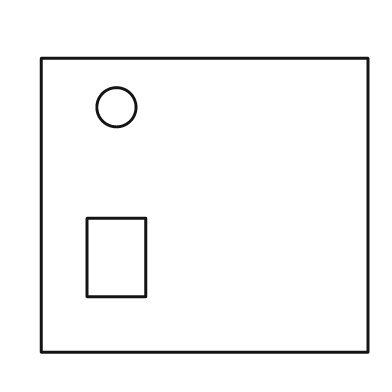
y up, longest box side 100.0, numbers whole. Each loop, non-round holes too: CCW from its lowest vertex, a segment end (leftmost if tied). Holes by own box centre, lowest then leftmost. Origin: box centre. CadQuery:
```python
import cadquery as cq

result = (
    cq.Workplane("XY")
    .moveTo(-50.0, -45.0)
    .lineTo(50.0, -45.0)
    .lineTo(50.0, 45.0)
    .lineTo(-50.0, 45.0)
    .close()
    .moveTo(-36.0, -28.0)
    .lineTo(-18.0, -28.0)
    .lineTo(-18.0, -4.0)
    .lineTo(-36.0, -4.0)
    .close()
    .moveTo(-27.0, 30.0)
    .circle(6.0)
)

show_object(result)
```